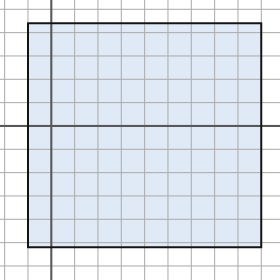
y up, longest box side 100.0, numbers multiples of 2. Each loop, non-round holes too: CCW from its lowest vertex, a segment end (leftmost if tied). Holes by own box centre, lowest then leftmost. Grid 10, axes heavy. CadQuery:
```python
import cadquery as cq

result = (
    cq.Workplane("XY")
    .moveTo(-10.0, -52.0)
    .lineTo(90.0, -52.0)
    .lineTo(90.0, 44.0)
    .lineTo(-10.0, 44.0)
    .close()
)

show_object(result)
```